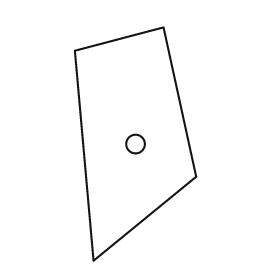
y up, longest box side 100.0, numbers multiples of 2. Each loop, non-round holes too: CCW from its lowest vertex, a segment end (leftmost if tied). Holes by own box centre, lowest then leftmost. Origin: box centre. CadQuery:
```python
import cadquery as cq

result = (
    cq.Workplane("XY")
    .moveTo(-18.0, -50.0)
    .lineTo(26.0, -14.0)
    .lineTo(12.0, 50.0)
    .lineTo(-26.0, 40.0)
    .close()
    .moveTo(0.0, 0.0)
    .circle(4.0)
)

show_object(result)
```